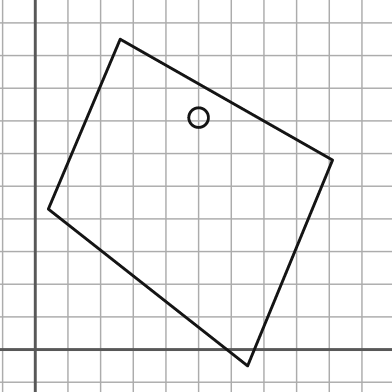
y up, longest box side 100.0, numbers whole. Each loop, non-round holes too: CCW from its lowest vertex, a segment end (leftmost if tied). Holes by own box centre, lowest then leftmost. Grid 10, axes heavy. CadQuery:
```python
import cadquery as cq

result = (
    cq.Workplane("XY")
    .moveTo(65.0, -5.0)
    .lineTo(91.0, 58.0)
    .lineTo(26.0, 95.0)
    .lineTo(4.0, 43.0)
    .close()
    .moveTo(50.0, 71.0)
    .circle(3.0)
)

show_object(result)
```